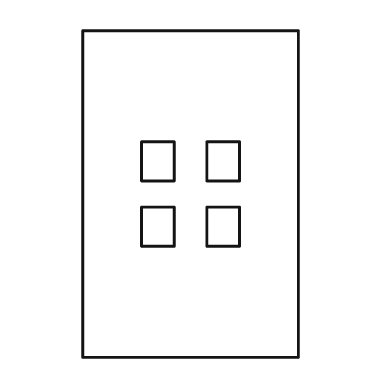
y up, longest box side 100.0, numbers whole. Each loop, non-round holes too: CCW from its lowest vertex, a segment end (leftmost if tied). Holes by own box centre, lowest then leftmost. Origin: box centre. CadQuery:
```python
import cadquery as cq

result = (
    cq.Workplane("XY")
    .moveTo(-33.0, -50.0)
    .lineTo(33.0, -50.0)
    .lineTo(33.0, 50.0)
    .lineTo(-33.0, 50.0)
    .close()
    .moveTo(-15.0, -16.0)
    .lineTo(-5.0, -16.0)
    .lineTo(-5.0, -4.0)
    .lineTo(-15.0, -4.0)
    .close()
    .moveTo(5.0, -16.0)
    .lineTo(15.0, -16.0)
    .lineTo(15.0, -4.0)
    .lineTo(5.0, -4.0)
    .close()
    .moveTo(-15.0, 4.0)
    .lineTo(-5.0, 4.0)
    .lineTo(-5.0, 16.0)
    .lineTo(-15.0, 16.0)
    .close()
    .moveTo(5.0, 4.0)
    .lineTo(15.0, 4.0)
    .lineTo(15.0, 16.0)
    .lineTo(5.0, 16.0)
    .close()
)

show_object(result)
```